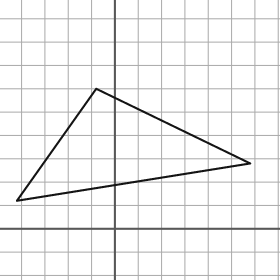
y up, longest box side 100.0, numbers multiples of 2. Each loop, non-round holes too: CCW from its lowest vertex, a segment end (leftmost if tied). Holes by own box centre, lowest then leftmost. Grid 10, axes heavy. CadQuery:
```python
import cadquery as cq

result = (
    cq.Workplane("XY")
    .moveTo(-42.0, 12.0)
    .lineTo(58.0, 28.0)
    .lineTo(-8.0, 60.0)
    .close()
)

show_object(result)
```